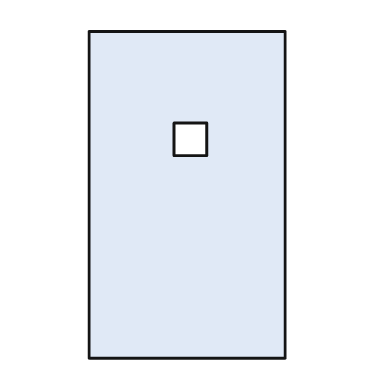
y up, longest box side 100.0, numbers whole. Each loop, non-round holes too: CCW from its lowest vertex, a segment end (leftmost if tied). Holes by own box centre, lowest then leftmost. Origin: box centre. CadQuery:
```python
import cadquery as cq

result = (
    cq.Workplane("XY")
    .moveTo(-30.0, -50.0)
    .lineTo(30.0, -50.0)
    .lineTo(30.0, 50.0)
    .lineTo(-30.0, 50.0)
    .close()
    .moveTo(-4.0, 12.0)
    .lineTo(6.0, 12.0)
    .lineTo(6.0, 22.0)
    .lineTo(-4.0, 22.0)
    .close()
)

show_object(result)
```